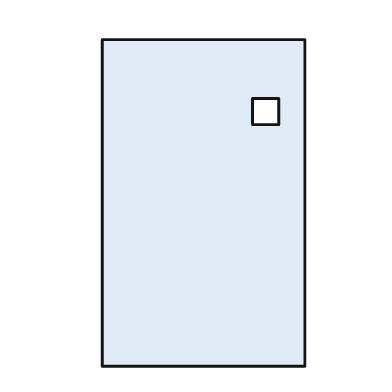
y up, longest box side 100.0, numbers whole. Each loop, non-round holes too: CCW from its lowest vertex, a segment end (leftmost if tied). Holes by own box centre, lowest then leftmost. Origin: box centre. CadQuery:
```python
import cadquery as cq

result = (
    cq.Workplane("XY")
    .moveTo(-31.0, -50.0)
    .lineTo(31.0, -50.0)
    .lineTo(31.0, 50.0)
    .lineTo(-31.0, 50.0)
    .close()
    .moveTo(15.0, 24.0)
    .lineTo(23.0, 24.0)
    .lineTo(23.0, 32.0)
    .lineTo(15.0, 32.0)
    .close()
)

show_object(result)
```